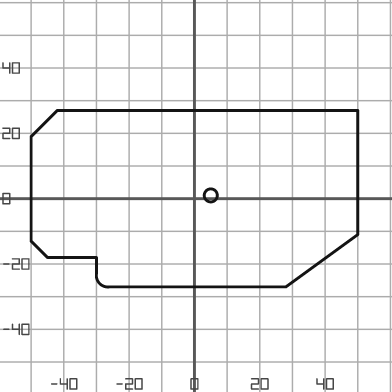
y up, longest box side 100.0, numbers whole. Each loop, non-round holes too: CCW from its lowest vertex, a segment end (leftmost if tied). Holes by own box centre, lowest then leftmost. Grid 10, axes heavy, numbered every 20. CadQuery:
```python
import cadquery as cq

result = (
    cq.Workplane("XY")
    .moveTo(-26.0, -27.0)
    .lineTo(28.0, -27.0)
    .lineTo(50.0, -11.0)
    .lineTo(50.0, 27.0)
    .lineTo(-42.0, 27.0)
    .lineTo(-50.0, 19.0)
    .lineTo(-50.0, -13.0)
    .lineTo(-45.0, -18.0)
    .lineTo(-30.0, -18.0)
    .lineTo(-30.0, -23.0)
    .threePointArc((-29.0, -26.0), (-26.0, -27.0))
    .close()
    .moveTo(5.0, 1.0)
    .circle(2.0)
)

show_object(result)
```